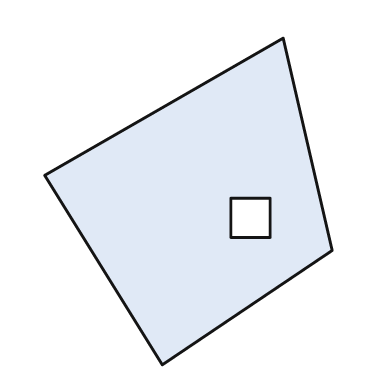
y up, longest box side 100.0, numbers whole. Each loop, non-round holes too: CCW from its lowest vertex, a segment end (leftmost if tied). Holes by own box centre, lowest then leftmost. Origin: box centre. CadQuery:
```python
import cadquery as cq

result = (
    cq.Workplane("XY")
    .moveTo(-8.0, -50.0)
    .lineTo(44.0, -15.0)
    .lineTo(29.0, 50.0)
    .lineTo(-44.0, 8.0)
    .close()
    .moveTo(13.0, -11.0)
    .lineTo(25.0, -11.0)
    .lineTo(25.0, 1.0)
    .lineTo(13.0, 1.0)
    .close()
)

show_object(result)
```